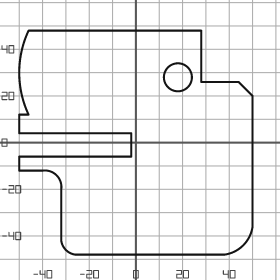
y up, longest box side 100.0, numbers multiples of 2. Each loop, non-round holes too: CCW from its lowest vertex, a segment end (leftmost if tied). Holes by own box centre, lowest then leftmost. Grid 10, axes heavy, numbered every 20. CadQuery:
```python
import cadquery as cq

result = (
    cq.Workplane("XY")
    .moveTo(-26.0, -48.0)
    .lineTo(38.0, -48.0)
    .threePointArc((46.0, -44.0), (50.0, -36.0))
    .lineTo(50.0, 20.0)
    .lineTo(44.0, 26.0)
    .lineTo(28.0, 26.0)
    .lineTo(28.0, 48.0)
    .lineTo(-46.0, 48.0)
    .threePointArc((-50.0, 30.0), (-46.0, 12.0))
    .lineTo(-50.0, 12.0)
    .lineTo(-50.0, 4.0)
    .lineTo(-2.0, 4.0)
    .lineTo(-2.0, -6.0)
    .lineTo(-50.0, -6.0)
    .lineTo(-50.0, -12.0)
    .lineTo(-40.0, -12.0)
    .threePointArc((-34.0, -14.0), (-32.0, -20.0))
    .lineTo(-32.0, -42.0)
    .threePointArc((-30.0, -46.0), (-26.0, -48.0))
    .close()
    .moveTo(18.0, 28.0)
    .circle(6.0)
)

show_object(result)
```